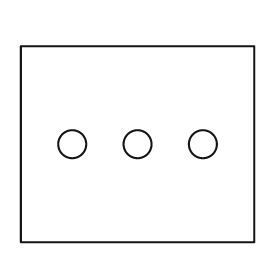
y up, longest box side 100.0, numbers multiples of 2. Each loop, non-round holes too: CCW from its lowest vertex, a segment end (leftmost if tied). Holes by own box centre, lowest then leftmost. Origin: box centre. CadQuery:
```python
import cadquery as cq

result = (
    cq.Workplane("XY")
    .moveTo(-50.0, -42.0)
    .lineTo(50.0, -42.0)
    .lineTo(50.0, 42.0)
    .lineTo(-50.0, 42.0)
    .close()
    .moveTo(-28.0, 0.0)
    .circle(6.0)
    .moveTo(0.0, 0.0)
    .circle(6.0)
    .moveTo(28.0, 0.0)
    .circle(6.0)
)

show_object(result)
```